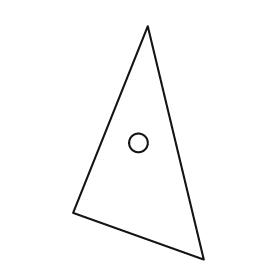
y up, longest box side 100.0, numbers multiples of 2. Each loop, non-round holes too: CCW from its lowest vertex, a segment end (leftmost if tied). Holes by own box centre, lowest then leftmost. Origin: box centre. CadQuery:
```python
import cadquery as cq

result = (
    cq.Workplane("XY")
    .moveTo(28.0, -50.0)
    .lineTo(4.0, 50.0)
    .lineTo(-28.0, -30.0)
    .close()
    .moveTo(0.0, 0.0)
    .circle(4.0)
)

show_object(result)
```